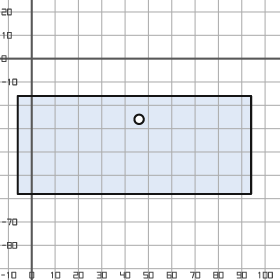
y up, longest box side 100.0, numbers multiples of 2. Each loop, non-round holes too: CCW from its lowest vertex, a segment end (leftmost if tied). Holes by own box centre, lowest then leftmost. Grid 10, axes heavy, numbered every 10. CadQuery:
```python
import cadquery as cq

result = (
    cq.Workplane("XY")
    .moveTo(-6.0, -58.0)
    .lineTo(94.0, -58.0)
    .lineTo(94.0, -16.0)
    .lineTo(-6.0, -16.0)
    .close()
    .moveTo(46.0, -26.0)
    .circle(2.0)
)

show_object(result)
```